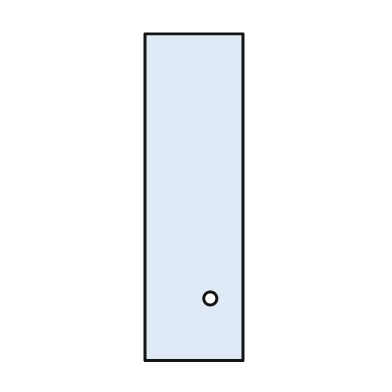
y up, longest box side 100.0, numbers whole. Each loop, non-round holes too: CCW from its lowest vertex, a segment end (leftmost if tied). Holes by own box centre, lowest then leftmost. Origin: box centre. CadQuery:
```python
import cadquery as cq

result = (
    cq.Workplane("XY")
    .moveTo(-15.0, -50.0)
    .lineTo(15.0, -50.0)
    .lineTo(15.0, 50.0)
    .lineTo(-15.0, 50.0)
    .close()
    .moveTo(5.0, -31.0)
    .circle(2.0)
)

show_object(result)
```